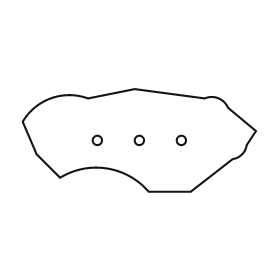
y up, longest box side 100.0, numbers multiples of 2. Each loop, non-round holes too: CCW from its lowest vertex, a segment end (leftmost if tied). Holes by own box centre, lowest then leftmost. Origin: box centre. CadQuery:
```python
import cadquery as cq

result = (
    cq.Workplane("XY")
    .moveTo(4.0, -22.0)
    .lineTo(22.0, -22.0)
    .lineTo(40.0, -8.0)
    .threePointArc((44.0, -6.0), (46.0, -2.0))
    .lineTo(50.0, 4.0)
    .lineTo(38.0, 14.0)
    .threePointArc((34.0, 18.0), (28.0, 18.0))
    .lineTo(-2.0, 22.0)
    .lineTo(-22.0, 18.0)
    .threePointArc((-38.0, 18.0), (-50.0, 8.0))
    .lineTo(-44.0, -6.0)
    .lineTo(-34.0, -16.0)
    .threePointArc((-14.0, -12.0), (4.0, -22.0))
    .close()
    .moveTo(-18.0, 0.0)
    .circle(2.0)
    .moveTo(0.0, 0.0)
    .circle(2.0)
    .moveTo(18.0, 0.0)
    .circle(2.0)
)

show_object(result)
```